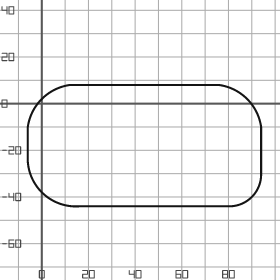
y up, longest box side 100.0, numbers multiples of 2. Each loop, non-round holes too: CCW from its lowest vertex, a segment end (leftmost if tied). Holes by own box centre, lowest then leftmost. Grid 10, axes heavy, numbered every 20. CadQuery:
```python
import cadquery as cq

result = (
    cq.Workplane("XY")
    .moveTo(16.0, -44.0)
    .lineTo(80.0, -44.0)
    .threePointArc((90.0, -40.0), (94.0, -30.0))
    .lineTo(94.0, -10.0)
    .threePointArc((88.0, 2.0), (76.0, 8.0))
    .lineTo(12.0, 8.0)
    .threePointArc((0.0, 2.0), (-6.0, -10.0))
    .lineTo(-6.0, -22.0)
    .threePointArc((0.0, -38.0), (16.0, -44.0))
    .close()
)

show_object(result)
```